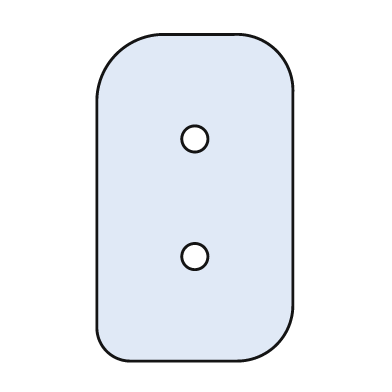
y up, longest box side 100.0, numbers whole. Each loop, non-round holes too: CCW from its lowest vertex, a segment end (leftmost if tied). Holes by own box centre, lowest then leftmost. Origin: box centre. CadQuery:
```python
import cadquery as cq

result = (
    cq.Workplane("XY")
    .moveTo(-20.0, -50.0)
    .lineTo(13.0, -50.0)
    .threePointArc((25.0, -45.0), (30.0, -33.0))
    .lineTo(30.0, 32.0)
    .threePointArc((25.0, 45.0), (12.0, 50.0))
    .lineTo(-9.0, 50.0)
    .threePointArc((-24.0, 44.0), (-30.0, 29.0))
    .lineTo(-30.0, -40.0)
    .threePointArc((-27.0, -47.0), (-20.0, -50.0))
    .close()
    .moveTo(0.0, -18.0)
    .circle(4.0)
    .moveTo(0.0, 18.0)
    .circle(4.0)
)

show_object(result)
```